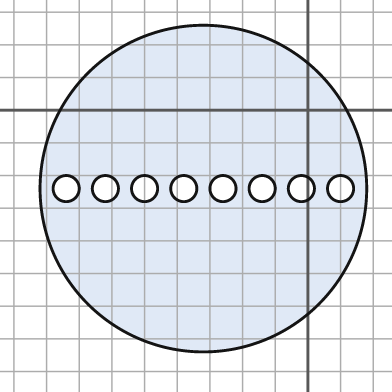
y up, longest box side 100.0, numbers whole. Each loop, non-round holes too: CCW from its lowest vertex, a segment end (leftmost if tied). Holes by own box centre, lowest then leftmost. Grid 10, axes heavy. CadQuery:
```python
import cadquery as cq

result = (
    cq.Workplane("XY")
    .moveTo(-32.0, -24.0)
    .circle(50.0)
    .moveTo(-74.0, -24.0)
    .circle(4.0)
    .moveTo(-62.0, -24.0)
    .circle(4.0)
    .moveTo(-50.0, -24.0)
    .circle(4.0)
    .moveTo(-38.0, -24.0)
    .circle(4.0)
    .moveTo(-26.0, -24.0)
    .circle(4.0)
    .moveTo(-14.0, -24.0)
    .circle(4.0)
    .moveTo(-2.0, -24.0)
    .circle(4.0)
    .moveTo(10.0, -24.0)
    .circle(4.0)
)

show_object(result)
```